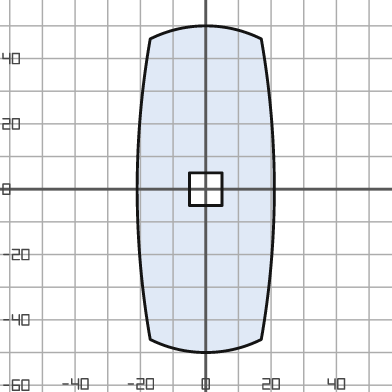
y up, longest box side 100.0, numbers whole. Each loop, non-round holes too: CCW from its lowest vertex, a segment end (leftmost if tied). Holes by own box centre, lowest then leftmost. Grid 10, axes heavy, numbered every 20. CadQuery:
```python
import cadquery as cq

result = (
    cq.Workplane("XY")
    .moveTo(-17.0, -46.0)
    .threePointArc((0.0, -50.0), (17.0, -46.0))
    .threePointArc((21.0, 0.0), (17.0, 46.0))
    .threePointArc((0.0, 50.0), (-17.0, 46.0))
    .threePointArc((-21.0, 0.0), (-17.0, -46.0))
    .close()
    .moveTo(-5.0, -5.0)
    .lineTo(5.0, -5.0)
    .lineTo(5.0, 5.0)
    .lineTo(-5.0, 5.0)
    .close()
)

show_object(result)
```